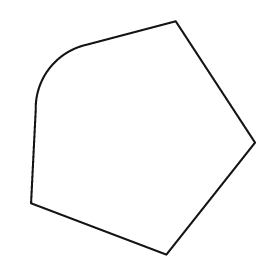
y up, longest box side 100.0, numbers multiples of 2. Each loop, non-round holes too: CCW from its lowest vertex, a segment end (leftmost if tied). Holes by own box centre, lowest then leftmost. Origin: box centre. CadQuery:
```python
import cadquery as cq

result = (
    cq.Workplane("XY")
    .moveTo(10.0, -50.0)
    .lineTo(48.0, -2.0)
    .lineTo(14.0, 50.0)
    .lineTo(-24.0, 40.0)
    .threePointArc((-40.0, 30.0), (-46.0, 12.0))
    .lineTo(-48.0, -28.0)
    .close()
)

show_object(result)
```